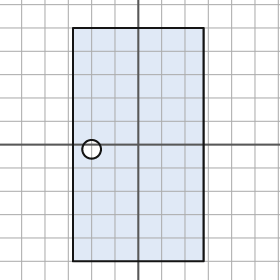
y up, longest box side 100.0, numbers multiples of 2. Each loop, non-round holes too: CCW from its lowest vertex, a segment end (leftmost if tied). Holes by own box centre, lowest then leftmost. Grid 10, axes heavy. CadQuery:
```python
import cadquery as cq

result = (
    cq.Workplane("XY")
    .moveTo(-28.0, -50.0)
    .lineTo(28.0, -50.0)
    .lineTo(28.0, 50.0)
    .lineTo(-28.0, 50.0)
    .close()
    .moveTo(-20.0, -2.0)
    .circle(4.0)
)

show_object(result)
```